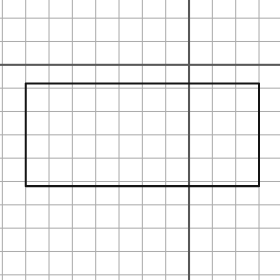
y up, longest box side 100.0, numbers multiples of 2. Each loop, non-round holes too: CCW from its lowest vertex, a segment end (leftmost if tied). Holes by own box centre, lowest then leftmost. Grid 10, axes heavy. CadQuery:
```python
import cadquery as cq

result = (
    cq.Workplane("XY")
    .moveTo(-70.0, -52.0)
    .lineTo(30.0, -52.0)
    .lineTo(30.0, -8.0)
    .lineTo(-70.0, -8.0)
    .close()
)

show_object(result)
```